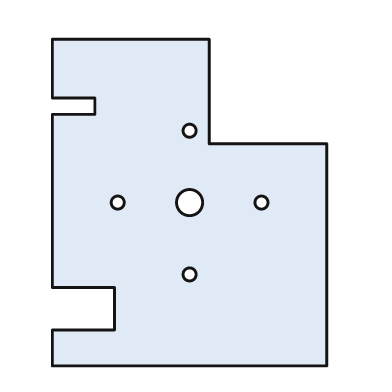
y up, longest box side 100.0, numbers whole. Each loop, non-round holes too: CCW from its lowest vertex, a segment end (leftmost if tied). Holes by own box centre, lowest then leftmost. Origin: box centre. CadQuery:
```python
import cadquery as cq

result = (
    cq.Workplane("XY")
    .moveTo(-42.0, -50.0)
    .lineTo(42.0, -50.0)
    .lineTo(42.0, 18.0)
    .lineTo(6.0, 18.0)
    .lineTo(6.0, 50.0)
    .lineTo(-42.0, 50.0)
    .lineTo(-42.0, 32.0)
    .lineTo(-29.0, 32.0)
    .lineTo(-29.0, 27.0)
    .lineTo(-42.0, 27.0)
    .lineTo(-42.0, -26.0)
    .lineTo(-23.0, -26.0)
    .lineTo(-23.0, -39.0)
    .lineTo(-42.0, -39.0)
    .close()
    .moveTo(0.0, -22.0)
    .circle(2.0)
    .moveTo(-22.0, 0.0)
    .circle(2.0)
    .moveTo(0.0, 0.0)
    .circle(4.0)
    .moveTo(22.0, 0.0)
    .circle(2.0)
    .moveTo(0.0, 22.0)
    .circle(2.0)
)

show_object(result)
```